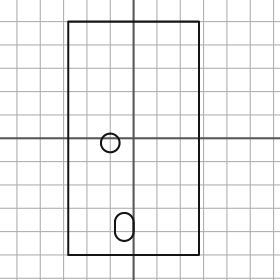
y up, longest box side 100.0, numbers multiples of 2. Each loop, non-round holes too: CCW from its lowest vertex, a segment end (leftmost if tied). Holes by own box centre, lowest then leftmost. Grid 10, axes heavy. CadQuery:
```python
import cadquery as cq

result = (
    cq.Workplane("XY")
    .moveTo(-28.0, -50.0)
    .lineTo(28.0, -50.0)
    .lineTo(28.0, 50.0)
    .lineTo(-28.0, 50.0)
    .close()
    .moveTo(-8.0, -40.0)
    .threePointArc((-4.0, -44.0), (0.0, -40.0))
    .lineTo(0.0, -36.0)
    .threePointArc((-4.0, -32.0), (-8.0, -36.0))
    .close()
    .moveTo(-10.0, -2.0)
    .circle(4.0)
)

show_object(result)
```